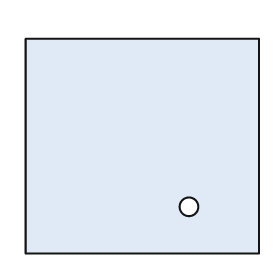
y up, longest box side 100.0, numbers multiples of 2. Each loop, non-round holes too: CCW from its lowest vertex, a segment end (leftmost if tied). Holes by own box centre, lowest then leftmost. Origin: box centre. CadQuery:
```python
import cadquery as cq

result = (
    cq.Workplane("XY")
    .moveTo(-50.0, -46.0)
    .lineTo(50.0, -46.0)
    .lineTo(50.0, 46.0)
    .lineTo(-50.0, 46.0)
    .close()
    .moveTo(20.0, -26.0)
    .circle(4.0)
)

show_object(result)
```